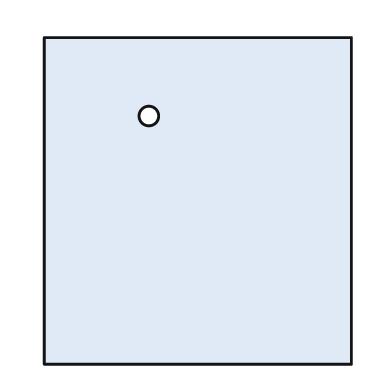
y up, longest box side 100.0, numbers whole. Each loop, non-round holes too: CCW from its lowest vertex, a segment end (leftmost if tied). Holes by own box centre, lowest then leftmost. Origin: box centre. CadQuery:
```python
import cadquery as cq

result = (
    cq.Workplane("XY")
    .moveTo(-47.0, -50.0)
    .lineTo(47.0, -50.0)
    .lineTo(47.0, 50.0)
    .lineTo(-47.0, 50.0)
    .close()
    .moveTo(-15.0, 26.0)
    .circle(3.0)
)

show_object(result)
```